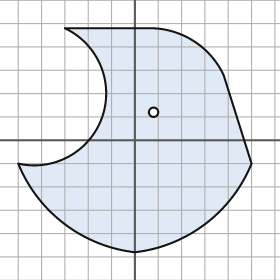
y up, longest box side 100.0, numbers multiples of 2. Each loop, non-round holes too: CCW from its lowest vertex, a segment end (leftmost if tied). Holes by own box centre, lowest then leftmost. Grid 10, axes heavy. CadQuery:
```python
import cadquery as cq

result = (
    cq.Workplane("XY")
    .moveTo(0.0, -48.0)
    .threePointArc((30.0, -36.0), (50.0, -10.0))
    .lineTo(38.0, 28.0)
    .threePointArc((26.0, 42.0), (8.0, 48.0))
    .lineTo(-30.0, 48.0)
    .threePointArc((-14.0, 10.0), (-50.0, -10.0))
    .threePointArc((-30.0, -36.0), (0.0, -48.0))
    .close()
    .moveTo(8.0, 12.0)
    .circle(2.0)
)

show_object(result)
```